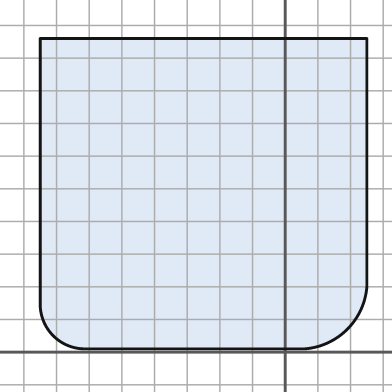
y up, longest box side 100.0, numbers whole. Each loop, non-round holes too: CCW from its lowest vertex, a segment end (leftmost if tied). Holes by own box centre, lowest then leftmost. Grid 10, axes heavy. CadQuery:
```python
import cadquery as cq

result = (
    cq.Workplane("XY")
    .moveTo(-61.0, 1.0)
    .lineTo(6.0, 1.0)
    .threePointArc((19.0, 7.0), (25.0, 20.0))
    .lineTo(25.0, 96.0)
    .lineTo(-75.0, 96.0)
    .lineTo(-75.0, 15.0)
    .threePointArc((-71.0, 5.0), (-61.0, 1.0))
    .close()
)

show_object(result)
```